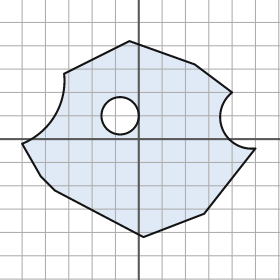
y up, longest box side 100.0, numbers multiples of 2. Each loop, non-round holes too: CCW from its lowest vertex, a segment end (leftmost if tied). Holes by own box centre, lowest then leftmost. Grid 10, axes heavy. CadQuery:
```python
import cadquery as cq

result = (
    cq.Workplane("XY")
    .moveTo(2.0, -42.0)
    .lineTo(28.0, -32.0)
    .lineTo(50.0, -4.0)
    .threePointArc((36.0, 4.0), (40.0, 20.0))
    .lineTo(24.0, 32.0)
    .lineTo(-4.0, 42.0)
    .lineTo(-32.0, 28.0)
    .threePointArc((-36.0, 10.0), (-50.0, -2.0))
    .lineTo(-42.0, -16.0)
    .lineTo(-36.0, -22.0)
    .close()
    .moveTo(-8.0, 10.0)
    .circle(8.0)
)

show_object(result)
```